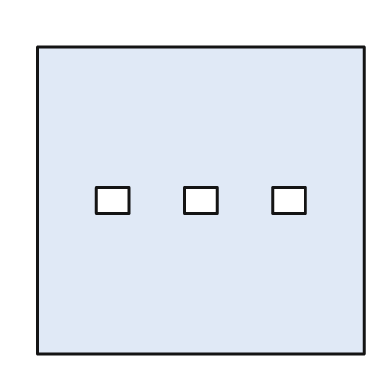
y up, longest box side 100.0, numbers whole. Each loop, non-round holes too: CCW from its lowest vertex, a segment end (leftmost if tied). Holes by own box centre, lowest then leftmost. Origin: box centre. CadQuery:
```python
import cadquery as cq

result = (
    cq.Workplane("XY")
    .moveTo(-50.0, -47.0)
    .lineTo(50.0, -47.0)
    .lineTo(50.0, 47.0)
    .lineTo(-50.0, 47.0)
    .close()
    .moveTo(-32.0, -4.0)
    .lineTo(-22.0, -4.0)
    .lineTo(-22.0, 4.0)
    .lineTo(-32.0, 4.0)
    .close()
    .moveTo(-5.0, -4.0)
    .lineTo(5.0, -4.0)
    .lineTo(5.0, 4.0)
    .lineTo(-5.0, 4.0)
    .close()
    .moveTo(22.0, -4.0)
    .lineTo(32.0, -4.0)
    .lineTo(32.0, 4.0)
    .lineTo(22.0, 4.0)
    .close()
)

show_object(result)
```